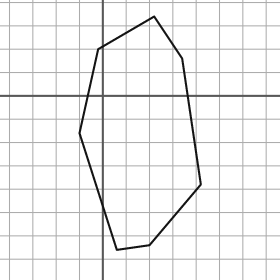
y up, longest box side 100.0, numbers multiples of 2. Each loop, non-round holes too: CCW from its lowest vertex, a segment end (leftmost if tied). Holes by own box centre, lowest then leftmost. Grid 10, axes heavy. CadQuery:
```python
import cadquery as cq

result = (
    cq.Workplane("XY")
    .moveTo(6.0, -66.0)
    .lineTo(20.0, -64.0)
    .lineTo(42.0, -38.0)
    .lineTo(34.0, 16.0)
    .lineTo(22.0, 34.0)
    .lineTo(-2.0, 20.0)
    .lineTo(-10.0, -16.0)
    .close()
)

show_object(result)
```